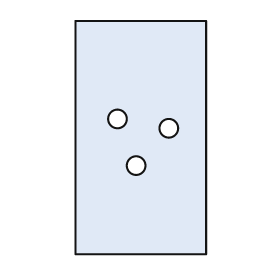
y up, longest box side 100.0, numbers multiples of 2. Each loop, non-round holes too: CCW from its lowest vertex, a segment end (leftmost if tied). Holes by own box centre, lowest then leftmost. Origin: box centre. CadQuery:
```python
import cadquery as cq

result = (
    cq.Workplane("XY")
    .moveTo(-28.0, -50.0)
    .lineTo(28.0, -50.0)
    .lineTo(28.0, 50.0)
    .lineTo(-28.0, 50.0)
    .close()
    .moveTo(-2.0, -12.0)
    .circle(4.0)
    .moveTo(12.0, 4.0)
    .circle(4.0)
    .moveTo(-10.0, 8.0)
    .circle(4.0)
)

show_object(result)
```